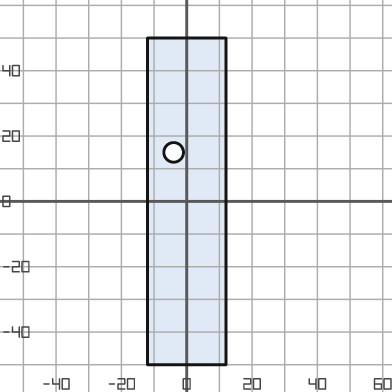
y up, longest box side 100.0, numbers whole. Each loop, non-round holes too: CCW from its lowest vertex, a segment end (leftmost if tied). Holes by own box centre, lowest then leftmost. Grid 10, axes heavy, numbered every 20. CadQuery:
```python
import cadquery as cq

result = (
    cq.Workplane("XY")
    .moveTo(-12.0, -50.0)
    .lineTo(12.0, -50.0)
    .lineTo(12.0, 50.0)
    .lineTo(-12.0, 50.0)
    .close()
    .moveTo(-4.0, 15.0)
    .circle(3.0)
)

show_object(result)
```